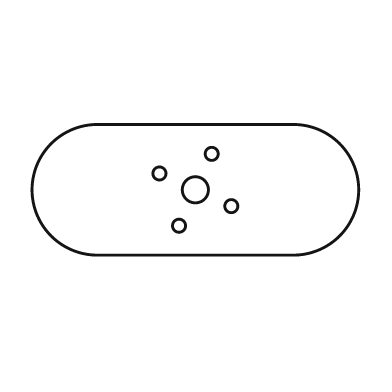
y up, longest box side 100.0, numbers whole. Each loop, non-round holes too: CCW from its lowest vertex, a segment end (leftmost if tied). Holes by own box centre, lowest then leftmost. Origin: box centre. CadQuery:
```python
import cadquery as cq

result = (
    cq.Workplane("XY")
    .moveTo(-30.0, -20.0)
    .lineTo(30.0, -20.0)
    .threePointArc((50.0, 0.0), (30.0, 20.0))
    .lineTo(-30.0, 20.0)
    .threePointArc((-50.0, 0.0), (-30.0, -20.0))
    .close()
    .moveTo(-5.0, -11.0)
    .circle(2.0)
    .moveTo(11.0, -5.0)
    .circle(2.0)
    .moveTo(0.0, 0.0)
    .circle(4.0)
    .moveTo(-11.0, 5.0)
    .circle(2.0)
    .moveTo(5.0, 11.0)
    .circle(2.0)
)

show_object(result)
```